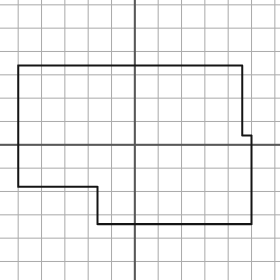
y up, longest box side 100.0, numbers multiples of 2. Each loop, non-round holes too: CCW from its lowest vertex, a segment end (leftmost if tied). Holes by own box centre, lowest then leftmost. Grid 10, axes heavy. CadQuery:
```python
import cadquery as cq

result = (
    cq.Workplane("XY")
    .moveTo(-16.0, -34.0)
    .lineTo(50.0, -34.0)
    .lineTo(50.0, 4.0)
    .lineTo(46.0, 4.0)
    .lineTo(46.0, 34.0)
    .lineTo(-50.0, 34.0)
    .lineTo(-50.0, -18.0)
    .lineTo(-16.0, -18.0)
    .close()
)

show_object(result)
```